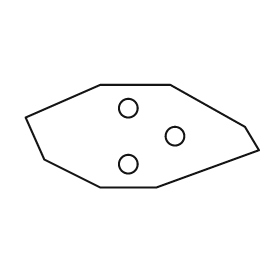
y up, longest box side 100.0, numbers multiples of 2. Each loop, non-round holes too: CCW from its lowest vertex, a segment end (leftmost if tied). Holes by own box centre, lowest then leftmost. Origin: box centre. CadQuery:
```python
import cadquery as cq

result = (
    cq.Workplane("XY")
    .moveTo(-18.0, -22.0)
    .lineTo(6.0, -22.0)
    .lineTo(50.0, -6.0)
    .lineTo(44.0, 4.0)
    .lineTo(12.0, 22.0)
    .lineTo(-18.0, 22.0)
    .lineTo(-50.0, 8.0)
    .lineTo(-42.0, -10.0)
    .close()
    .moveTo(-6.0, -12.0)
    .circle(4.0)
    .moveTo(14.0, 0.0)
    .circle(4.0)
    .moveTo(-6.0, 12.0)
    .circle(4.0)
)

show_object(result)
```